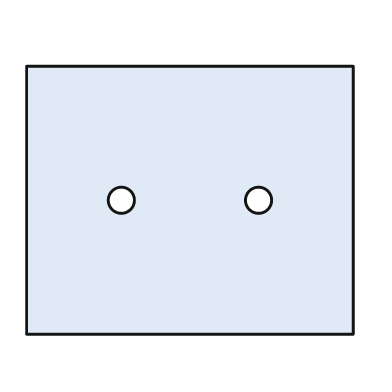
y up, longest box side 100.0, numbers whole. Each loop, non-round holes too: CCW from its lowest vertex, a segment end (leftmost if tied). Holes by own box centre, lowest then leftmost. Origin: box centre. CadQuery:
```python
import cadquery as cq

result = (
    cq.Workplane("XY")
    .moveTo(-50.0, -41.0)
    .lineTo(50.0, -41.0)
    .lineTo(50.0, 41.0)
    .lineTo(-50.0, 41.0)
    .close()
    .moveTo(-21.0, 0.0)
    .circle(4.0)
    .moveTo(21.0, 0.0)
    .circle(4.0)
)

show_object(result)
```